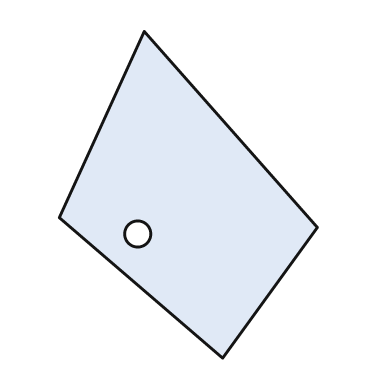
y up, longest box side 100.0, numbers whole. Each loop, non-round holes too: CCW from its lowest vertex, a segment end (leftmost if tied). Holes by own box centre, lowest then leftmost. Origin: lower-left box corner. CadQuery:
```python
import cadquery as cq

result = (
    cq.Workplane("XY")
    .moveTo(50.0, 0.0)
    .lineTo(79.0, 40.0)
    .lineTo(26.0, 100.0)
    .lineTo(0.0, 43.0)
    .close()
    .moveTo(24.0, 38.0)
    .circle(4.0)
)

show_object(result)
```